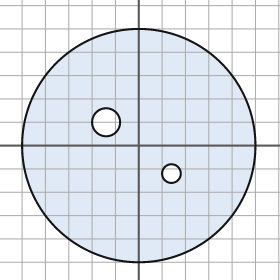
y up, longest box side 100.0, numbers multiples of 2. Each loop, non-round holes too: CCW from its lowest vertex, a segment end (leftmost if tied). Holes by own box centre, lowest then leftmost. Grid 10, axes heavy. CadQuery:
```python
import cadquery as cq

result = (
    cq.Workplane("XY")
    .moveTo(0.0, 0.0)
    .circle(50.0)
    .moveTo(14.0, -12.0)
    .circle(4.0)
    .moveTo(-14.0, 10.0)
    .circle(6.0)
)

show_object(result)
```